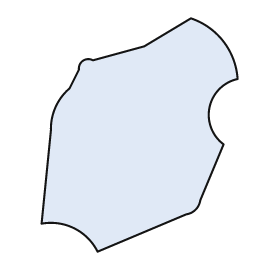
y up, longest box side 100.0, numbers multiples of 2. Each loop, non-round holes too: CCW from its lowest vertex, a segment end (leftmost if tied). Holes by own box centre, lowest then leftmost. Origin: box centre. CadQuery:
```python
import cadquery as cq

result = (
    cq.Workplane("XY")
    .moveTo(-18.0, -50.0)
    .lineTo(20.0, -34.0)
    .threePointArc((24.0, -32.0), (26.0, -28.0))
    .lineTo(36.0, -4.0)
    .threePointArc((30.0, 12.0), (42.0, 24.0))
    .threePointArc((36.0, 40.0), (22.0, 50.0))
    .lineTo(2.0, 38.0)
    .lineTo(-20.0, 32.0)
    .threePointArc((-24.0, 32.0), (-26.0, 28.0))
    .lineTo(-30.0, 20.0)
    .threePointArc((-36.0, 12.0), (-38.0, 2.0))
    .lineTo(-42.0, -38.0)
    .threePointArc((-28.0, -40.0), (-18.0, -50.0))
    .close()
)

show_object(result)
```